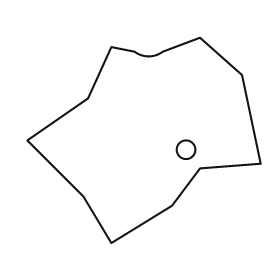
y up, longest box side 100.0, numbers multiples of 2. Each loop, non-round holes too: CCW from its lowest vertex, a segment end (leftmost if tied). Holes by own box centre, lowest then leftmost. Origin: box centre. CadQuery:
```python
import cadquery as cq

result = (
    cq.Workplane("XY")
    .moveTo(-14.0, -44.0)
    .lineTo(12.0, -28.0)
    .lineTo(24.0, -12.0)
    .lineTo(50.0, -10.0)
    .lineTo(42.0, 28.0)
    .lineTo(24.0, 44.0)
    .lineTo(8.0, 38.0)
    .threePointArc((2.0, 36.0), (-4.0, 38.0))
    .lineTo(-14.0, 40.0)
    .lineTo(-24.0, 18.0)
    .lineTo(-50.0, 0.0)
    .lineTo(-26.0, -24.0)
    .close()
    .moveTo(18.0, -4.0)
    .circle(4.0)
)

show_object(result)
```